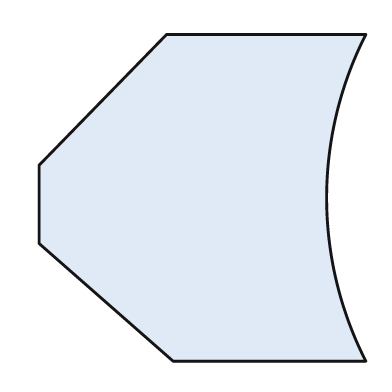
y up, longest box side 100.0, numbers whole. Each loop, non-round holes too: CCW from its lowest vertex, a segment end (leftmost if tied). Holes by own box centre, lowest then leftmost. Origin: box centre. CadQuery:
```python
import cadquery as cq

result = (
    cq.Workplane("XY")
    .moveTo(-9.0, -50.0)
    .lineTo(50.0, -50.0)
    .threePointArc((38.0, 0.0), (50.0, 50.0))
    .lineTo(-11.0, 50.0)
    .lineTo(-50.0, 10.0)
    .lineTo(-50.0, -14.0)
    .close()
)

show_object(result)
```